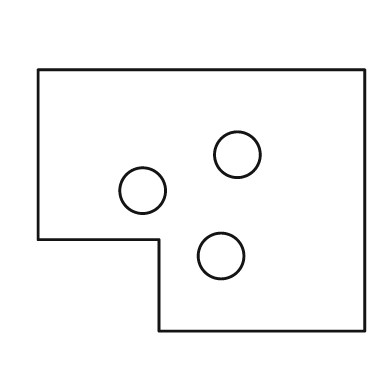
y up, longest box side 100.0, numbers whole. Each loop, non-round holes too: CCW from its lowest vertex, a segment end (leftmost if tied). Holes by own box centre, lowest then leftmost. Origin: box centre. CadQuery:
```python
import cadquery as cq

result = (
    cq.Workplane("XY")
    .moveTo(-13.0, -40.0)
    .lineTo(50.0, -40.0)
    .lineTo(50.0, 40.0)
    .lineTo(-50.0, 40.0)
    .lineTo(-50.0, -12.0)
    .lineTo(-13.0, -12.0)
    .close()
    .moveTo(6.0, -17.0)
    .circle(7.0)
    .moveTo(-18.0, 3.0)
    .circle(7.0)
    .moveTo(11.0, 14.0)
    .circle(7.0)
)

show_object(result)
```